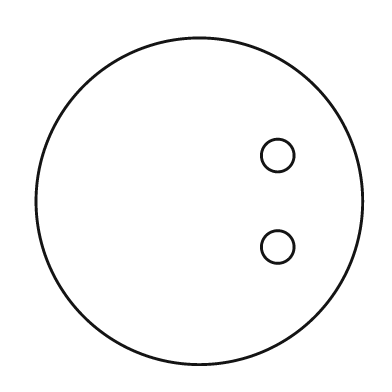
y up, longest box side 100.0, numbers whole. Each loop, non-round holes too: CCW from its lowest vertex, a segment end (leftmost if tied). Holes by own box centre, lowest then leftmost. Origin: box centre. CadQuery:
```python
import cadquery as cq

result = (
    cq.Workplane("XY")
    .moveTo(0.0, 0.0)
    .circle(50.0)
    .moveTo(24.0, -14.0)
    .circle(5.0)
    .moveTo(24.0, 14.0)
    .circle(5.0)
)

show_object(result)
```